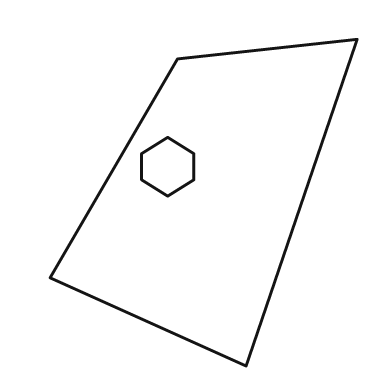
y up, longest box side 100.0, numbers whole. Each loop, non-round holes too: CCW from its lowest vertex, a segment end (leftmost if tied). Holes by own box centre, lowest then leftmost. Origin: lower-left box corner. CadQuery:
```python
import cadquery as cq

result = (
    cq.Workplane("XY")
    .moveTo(60.0, 0.0)
    .lineTo(94.0, 100.0)
    .lineTo(39.0, 94.0)
    .lineTo(0.0, 27.0)
    .close()
    .moveTo(36.0, 52.0)
    .lineTo(44.0, 57.0)
    .lineTo(44.0, 65.0)
    .lineTo(36.0, 70.0)
    .lineTo(28.0, 65.0)
    .lineTo(28.0, 57.0)
    .close()
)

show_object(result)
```